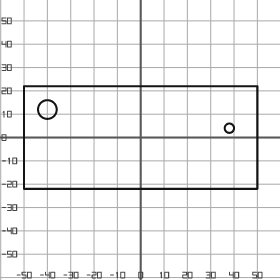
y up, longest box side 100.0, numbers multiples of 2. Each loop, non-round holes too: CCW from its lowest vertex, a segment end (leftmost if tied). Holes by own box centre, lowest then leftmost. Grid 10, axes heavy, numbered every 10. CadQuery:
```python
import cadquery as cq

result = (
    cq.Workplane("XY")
    .moveTo(-50.0, -22.0)
    .lineTo(50.0, -22.0)
    .lineTo(50.0, 22.0)
    .lineTo(-50.0, 22.0)
    .close()
    .moveTo(38.0, 4.0)
    .circle(2.0)
    .moveTo(-40.0, 12.0)
    .circle(4.0)
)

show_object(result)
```